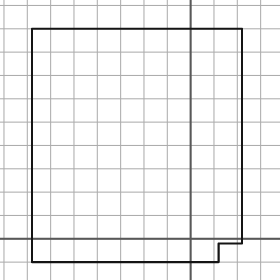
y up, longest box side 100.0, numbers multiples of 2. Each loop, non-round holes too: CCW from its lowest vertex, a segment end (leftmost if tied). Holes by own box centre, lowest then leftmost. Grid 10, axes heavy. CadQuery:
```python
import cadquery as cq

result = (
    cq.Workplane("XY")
    .moveTo(-68.0, -10.0)
    .lineTo(12.0, -10.0)
    .lineTo(12.0, -2.0)
    .lineTo(22.0, -2.0)
    .lineTo(22.0, 90.0)
    .lineTo(-68.0, 90.0)
    .close()
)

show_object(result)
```